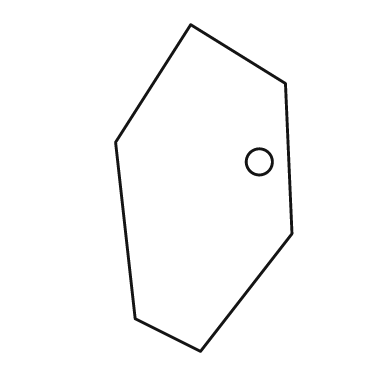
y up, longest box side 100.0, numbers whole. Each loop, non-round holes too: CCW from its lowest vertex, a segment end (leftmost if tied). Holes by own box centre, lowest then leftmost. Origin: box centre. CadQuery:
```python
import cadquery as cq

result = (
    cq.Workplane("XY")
    .moveTo(-1.0, -50.0)
    .lineTo(27.0, -14.0)
    .lineTo(25.0, 32.0)
    .lineTo(-4.0, 50.0)
    .lineTo(-27.0, 14.0)
    .lineTo(-21.0, -40.0)
    .close()
    .moveTo(17.0, 8.0)
    .circle(4.0)
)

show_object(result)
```